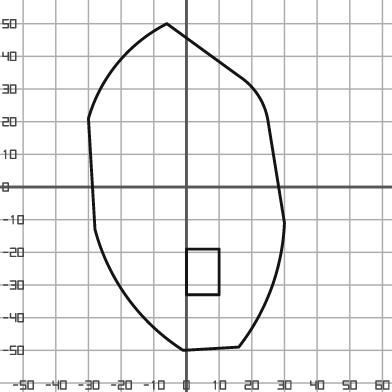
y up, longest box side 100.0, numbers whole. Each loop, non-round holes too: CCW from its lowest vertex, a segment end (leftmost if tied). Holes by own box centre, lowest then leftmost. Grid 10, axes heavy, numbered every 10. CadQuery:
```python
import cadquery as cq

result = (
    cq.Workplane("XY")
    .moveTo(-1.0, -50.0)
    .lineTo(16.0, -49.0)
    .threePointArc((26.0, -31.0), (30.0, -11.0))
    .lineTo(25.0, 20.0)
    .threePointArc((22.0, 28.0), (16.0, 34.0))
    .lineTo(-6.0, 50.0)
    .threePointArc((-21.0, 38.0), (-30.0, 21.0))
    .lineTo(-28.0, -13.0)
    .threePointArc((-18.0, -34.0), (-1.0, -50.0))
    .close()
    .moveTo(0.0, -33.0)
    .lineTo(10.0, -33.0)
    .lineTo(10.0, -19.0)
    .lineTo(0.0, -19.0)
    .close()
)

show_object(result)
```